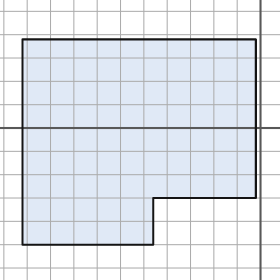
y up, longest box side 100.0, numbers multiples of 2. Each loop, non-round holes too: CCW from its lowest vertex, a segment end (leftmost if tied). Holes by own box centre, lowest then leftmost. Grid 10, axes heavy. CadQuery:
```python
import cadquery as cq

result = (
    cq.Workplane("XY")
    .moveTo(-102.0, -50.0)
    .lineTo(-46.0, -50.0)
    .lineTo(-46.0, -30.0)
    .lineTo(-2.0, -30.0)
    .lineTo(-2.0, 38.0)
    .lineTo(-102.0, 38.0)
    .close()
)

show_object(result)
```